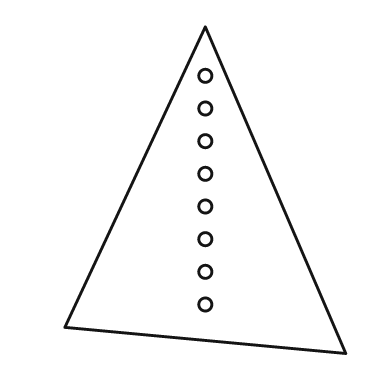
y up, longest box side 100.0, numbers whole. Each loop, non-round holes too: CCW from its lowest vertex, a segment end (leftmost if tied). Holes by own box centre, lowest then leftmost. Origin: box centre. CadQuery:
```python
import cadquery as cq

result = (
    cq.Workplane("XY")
    .moveTo(43.0, -50.0)
    .lineTo(0.0, 50.0)
    .lineTo(-43.0, -42.0)
    .close()
    .moveTo(0.0, -35.0)
    .circle(2.0)
    .moveTo(0.0, -25.0)
    .circle(2.0)
    .moveTo(0.0, -15.0)
    .circle(2.0)
    .moveTo(0.0, -5.0)
    .circle(2.0)
    .moveTo(0.0, 5.0)
    .circle(2.0)
    .moveTo(0.0, 15.0)
    .circle(2.0)
    .moveTo(0.0, 25.0)
    .circle(2.0)
    .moveTo(0.0, 35.0)
    .circle(2.0)
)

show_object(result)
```